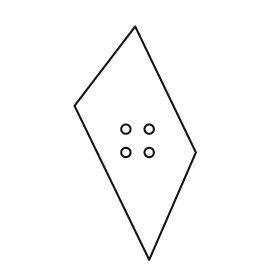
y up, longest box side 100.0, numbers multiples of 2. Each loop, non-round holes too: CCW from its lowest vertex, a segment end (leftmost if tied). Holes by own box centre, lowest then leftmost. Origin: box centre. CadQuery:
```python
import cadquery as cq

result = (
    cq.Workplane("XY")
    .moveTo(6.0, -50.0)
    .lineTo(26.0, -4.0)
    .lineTo(0.0, 50.0)
    .lineTo(-26.0, 16.0)
    .close()
    .moveTo(-4.0, -4.0)
    .circle(2.0)
    .moveTo(6.0, -4.0)
    .circle(2.0)
    .moveTo(-4.0, 6.0)
    .circle(2.0)
    .moveTo(6.0, 6.0)
    .circle(2.0)
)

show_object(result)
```